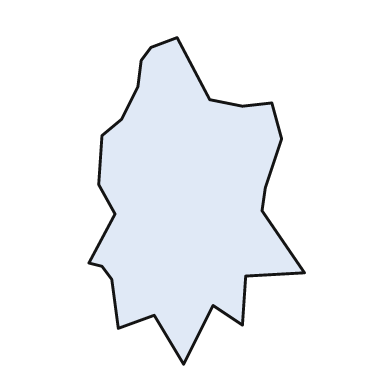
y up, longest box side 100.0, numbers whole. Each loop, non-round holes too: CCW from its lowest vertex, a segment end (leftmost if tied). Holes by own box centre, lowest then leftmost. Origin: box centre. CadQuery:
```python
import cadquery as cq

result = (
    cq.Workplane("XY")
    .moveTo(-4.0, -50.0)
    .lineTo(5.0, -32.0)
    .lineTo(14.0, -38.0)
    .lineTo(15.0, -23.0)
    .lineTo(33.0, -22.0)
    .lineTo(20.0, -3.0)
    .lineTo(21.0, 4.0)
    .lineTo(26.0, 19.0)
    .lineTo(23.0, 30.0)
    .lineTo(14.0, 29.0)
    .lineTo(4.0, 31.0)
    .lineTo(-6.0, 50.0)
    .lineTo(-14.0, 47.0)
    .lineTo(-17.0, 43.0)
    .lineTo(-18.0, 35.0)
    .lineTo(-23.0, 25.0)
    .lineTo(-29.0, 20.0)
    .lineTo(-30.0, 5.0)
    .lineTo(-25.0, -4.0)
    .lineTo(-33.0, -19.0)
    .lineTo(-29.0, -20.0)
    .lineTo(-26.0, -24.0)
    .lineTo(-24.0, -39.0)
    .lineTo(-13.0, -35.0)
    .close()
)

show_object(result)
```